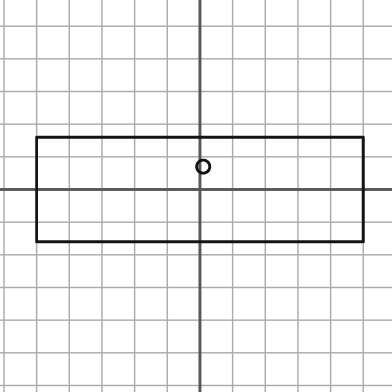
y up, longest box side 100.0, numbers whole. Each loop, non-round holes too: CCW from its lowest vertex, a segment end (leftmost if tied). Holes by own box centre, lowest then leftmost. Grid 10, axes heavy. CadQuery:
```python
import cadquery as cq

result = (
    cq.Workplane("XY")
    .moveTo(-50.0, -16.0)
    .lineTo(50.0, -16.0)
    .lineTo(50.0, 16.0)
    .lineTo(-50.0, 16.0)
    .close()
    .moveTo(1.0, 7.0)
    .circle(2.0)
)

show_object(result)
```